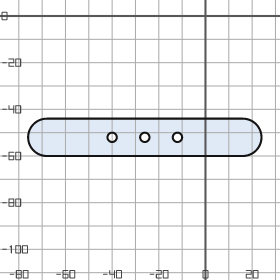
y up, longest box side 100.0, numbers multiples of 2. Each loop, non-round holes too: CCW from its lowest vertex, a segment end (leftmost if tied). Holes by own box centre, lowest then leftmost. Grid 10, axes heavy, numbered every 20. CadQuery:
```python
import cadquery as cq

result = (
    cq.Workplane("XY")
    .moveTo(-68.0, -60.0)
    .lineTo(16.0, -60.0)
    .threePointArc((24.0, -52.0), (16.0, -44.0))
    .lineTo(-68.0, -44.0)
    .threePointArc((-76.0, -52.0), (-68.0, -60.0))
    .close()
    .moveTo(-40.0, -52.0)
    .circle(2.0)
    .moveTo(-26.0, -52.0)
    .circle(2.0)
    .moveTo(-12.0, -52.0)
    .circle(2.0)
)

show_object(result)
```